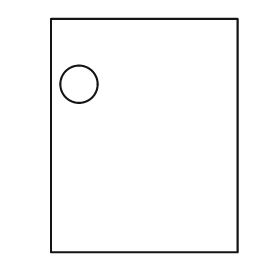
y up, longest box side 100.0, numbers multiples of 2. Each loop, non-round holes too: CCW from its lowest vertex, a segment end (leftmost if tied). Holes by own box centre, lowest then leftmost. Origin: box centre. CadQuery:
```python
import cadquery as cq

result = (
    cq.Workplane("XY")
    .moveTo(-40.0, -50.0)
    .lineTo(40.0, -50.0)
    .lineTo(40.0, 50.0)
    .lineTo(-40.0, 50.0)
    .close()
    .moveTo(-28.0, 22.0)
    .circle(8.0)
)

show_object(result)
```